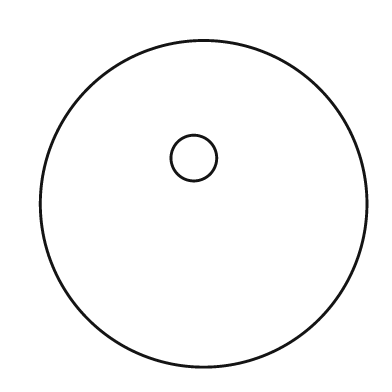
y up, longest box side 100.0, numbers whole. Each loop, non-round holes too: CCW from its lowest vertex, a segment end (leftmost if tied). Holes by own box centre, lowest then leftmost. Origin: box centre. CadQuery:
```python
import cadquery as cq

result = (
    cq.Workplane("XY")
    .moveTo(0.0, 0.0)
    .circle(50.0)
    .moveTo(-3.0, 14.0)
    .circle(7.0)
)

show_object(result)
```